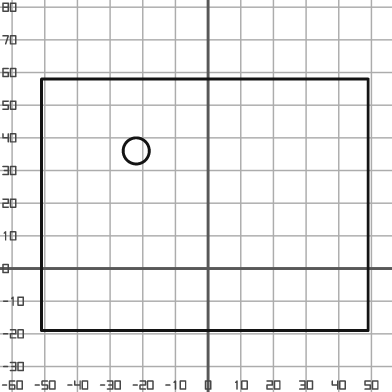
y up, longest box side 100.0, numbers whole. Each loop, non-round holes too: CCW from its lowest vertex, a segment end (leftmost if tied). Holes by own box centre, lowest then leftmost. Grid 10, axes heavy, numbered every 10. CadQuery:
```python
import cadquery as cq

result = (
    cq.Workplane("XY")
    .moveTo(-51.0, -19.0)
    .lineTo(49.0, -19.0)
    .lineTo(49.0, 58.0)
    .lineTo(-51.0, 58.0)
    .close()
    .moveTo(-22.0, 36.0)
    .circle(4.0)
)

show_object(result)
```